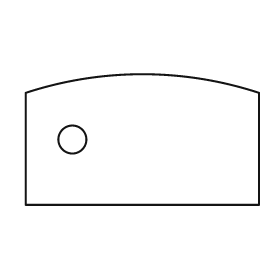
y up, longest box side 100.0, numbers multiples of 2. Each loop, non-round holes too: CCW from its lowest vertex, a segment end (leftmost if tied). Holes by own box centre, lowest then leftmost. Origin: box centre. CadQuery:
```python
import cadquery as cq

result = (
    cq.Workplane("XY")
    .moveTo(-50.0, -28.0)
    .lineTo(50.0, -28.0)
    .lineTo(50.0, 20.0)
    .threePointArc((0.0, 28.0), (-50.0, 20.0))
    .close()
    .moveTo(-30.0, 0.0)
    .circle(6.0)
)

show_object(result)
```